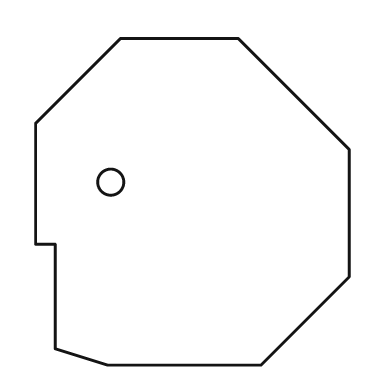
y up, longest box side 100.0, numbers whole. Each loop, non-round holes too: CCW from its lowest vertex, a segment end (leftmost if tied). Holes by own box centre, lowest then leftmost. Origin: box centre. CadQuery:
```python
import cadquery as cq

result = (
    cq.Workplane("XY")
    .moveTo(-26.0, -50.0)
    .lineTo(21.0, -50.0)
    .lineTo(48.0, -23.0)
    .lineTo(48.0, 16.0)
    .lineTo(14.0, 50.0)
    .lineTo(-22.0, 50.0)
    .lineTo(-48.0, 24.0)
    .lineTo(-48.0, -13.0)
    .lineTo(-42.0, -13.0)
    .lineTo(-42.0, -45.0)
    .close()
    .moveTo(-25.0, 6.0)
    .circle(4.0)
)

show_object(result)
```